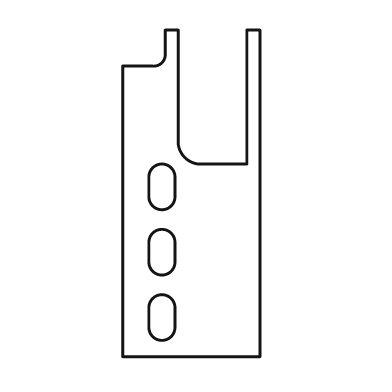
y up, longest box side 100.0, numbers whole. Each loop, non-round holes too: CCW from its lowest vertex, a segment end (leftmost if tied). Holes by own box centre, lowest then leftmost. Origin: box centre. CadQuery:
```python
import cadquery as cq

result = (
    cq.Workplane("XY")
    .moveTo(-21.0, -50.0)
    .lineTo(21.0, -50.0)
    .lineTo(21.0, 50.0)
    .lineTo(17.0, 50.0)
    .lineTo(17.0, 9.0)
    .lineTo(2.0, 9.0)
    .threePointArc((-2.0, 11.0), (-4.0, 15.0))
    .lineTo(-4.0, 50.0)
    .lineTo(-8.0, 50.0)
    .lineTo(-8.0, 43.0)
    .threePointArc((-9.0, 40.0), (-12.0, 39.0))
    .lineTo(-21.0, 39.0)
    .close()
    .moveTo(-13.0, -41.0)
    .threePointArc((-9.0, -45.0), (-5.0, -41.0))
    .lineTo(-5.0, -35.0)
    .threePointArc((-9.0, -31.0), (-13.0, -35.0))
    .close()
    .moveTo(-13.0, -21.0)
    .threePointArc((-9.0, -25.0), (-5.0, -21.0))
    .lineTo(-5.0, -15.0)
    .threePointArc((-9.0, -11.0), (-13.0, -15.0))
    .close()
    .moveTo(-13.0, -1.0)
    .threePointArc((-9.0, -5.0), (-5.0, -1.0))
    .lineTo(-5.0, 5.0)
    .threePointArc((-9.0, 9.0), (-13.0, 5.0))
    .close()
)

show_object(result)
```